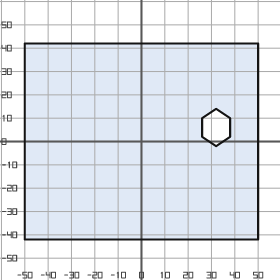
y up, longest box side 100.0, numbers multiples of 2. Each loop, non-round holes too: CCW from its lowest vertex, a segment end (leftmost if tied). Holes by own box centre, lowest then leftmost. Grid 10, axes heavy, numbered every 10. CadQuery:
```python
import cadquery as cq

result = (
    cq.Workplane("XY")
    .moveTo(-50.0, -42.0)
    .lineTo(50.0, -42.0)
    .lineTo(50.0, 42.0)
    .lineTo(-50.0, 42.0)
    .close()
    .moveTo(32.0, -2.0)
    .lineTo(38.0, 2.0)
    .lineTo(38.0, 10.0)
    .lineTo(32.0, 14.0)
    .lineTo(26.0, 10.0)
    .lineTo(26.0, 2.0)
    .close()
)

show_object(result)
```